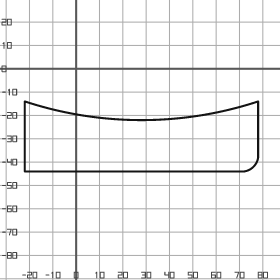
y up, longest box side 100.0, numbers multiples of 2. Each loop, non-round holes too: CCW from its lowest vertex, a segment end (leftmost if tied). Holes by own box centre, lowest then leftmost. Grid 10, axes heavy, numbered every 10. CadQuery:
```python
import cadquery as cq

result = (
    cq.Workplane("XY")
    .moveTo(-22.0, -44.0)
    .lineTo(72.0, -44.0)
    .threePointArc((76.0, -42.0), (78.0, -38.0))
    .lineTo(78.0, -14.0)
    .threePointArc((28.0, -22.0), (-22.0, -14.0))
    .close()
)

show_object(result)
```